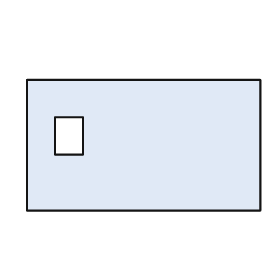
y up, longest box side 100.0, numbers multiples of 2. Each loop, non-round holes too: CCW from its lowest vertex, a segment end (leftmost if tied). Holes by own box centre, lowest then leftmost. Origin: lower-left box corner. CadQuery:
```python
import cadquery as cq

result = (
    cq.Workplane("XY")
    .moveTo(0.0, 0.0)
    .lineTo(100.0, 0.0)
    .lineTo(100.0, 56.0)
    .lineTo(0.0, 56.0)
    .close()
    .moveTo(12.0, 24.0)
    .lineTo(24.0, 24.0)
    .lineTo(24.0, 40.0)
    .lineTo(12.0, 40.0)
    .close()
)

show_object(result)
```